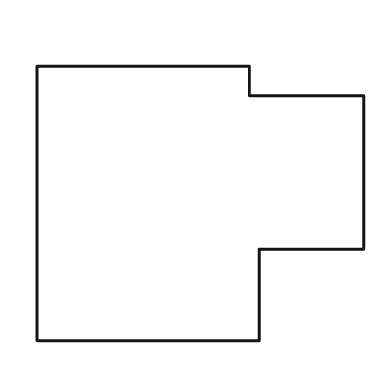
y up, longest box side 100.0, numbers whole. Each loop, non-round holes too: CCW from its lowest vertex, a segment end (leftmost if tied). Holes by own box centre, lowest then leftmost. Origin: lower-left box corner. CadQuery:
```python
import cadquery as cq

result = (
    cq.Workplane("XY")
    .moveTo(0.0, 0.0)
    .lineTo(68.0, 0.0)
    .lineTo(68.0, 28.0)
    .lineTo(100.0, 28.0)
    .lineTo(100.0, 75.0)
    .lineTo(65.0, 75.0)
    .lineTo(65.0, 84.0)
    .lineTo(0.0, 84.0)
    .close()
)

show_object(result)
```